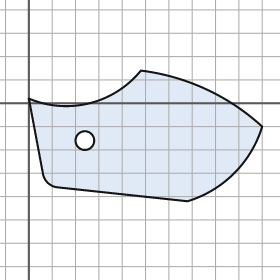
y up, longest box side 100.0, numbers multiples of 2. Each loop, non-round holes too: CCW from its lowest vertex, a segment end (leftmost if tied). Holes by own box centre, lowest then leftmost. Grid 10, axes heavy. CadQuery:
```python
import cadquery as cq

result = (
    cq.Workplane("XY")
    .moveTo(68.0, -42.0)
    .threePointArc((88.0, -30.0), (100.0, -10.0))
    .threePointArc((76.0, 6.0), (48.0, 14.0))
    .threePointArc((26.0, 0.0), (0.0, 2.0))
    .lineTo(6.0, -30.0)
    .threePointArc((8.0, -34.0), (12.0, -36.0))
    .close()
    .moveTo(24.0, -16.0)
    .circle(4.0)
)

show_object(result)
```